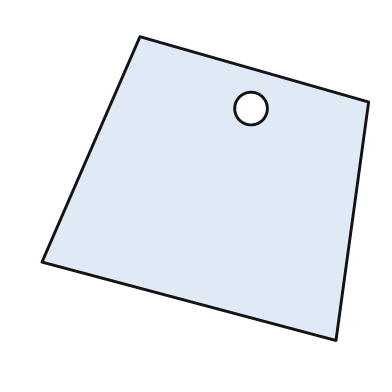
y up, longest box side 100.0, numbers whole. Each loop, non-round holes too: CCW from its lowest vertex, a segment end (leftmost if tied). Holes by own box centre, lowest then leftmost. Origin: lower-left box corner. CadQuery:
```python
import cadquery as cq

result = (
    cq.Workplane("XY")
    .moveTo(90.0, 0.0)
    .lineTo(100.0, 73.0)
    .lineTo(30.0, 93.0)
    .lineTo(0.0, 24.0)
    .close()
    .moveTo(64.0, 71.0)
    .circle(5.0)
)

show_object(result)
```